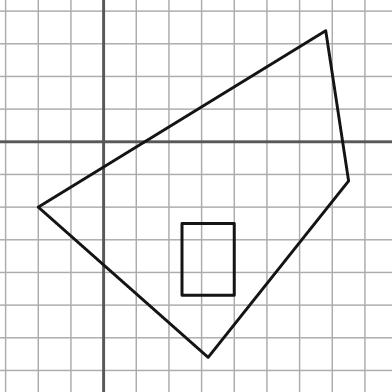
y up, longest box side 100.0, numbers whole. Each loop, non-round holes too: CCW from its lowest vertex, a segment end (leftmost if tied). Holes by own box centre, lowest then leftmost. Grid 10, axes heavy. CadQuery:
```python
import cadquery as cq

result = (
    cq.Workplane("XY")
    .moveTo(32.0, -66.0)
    .lineTo(75.0, -12.0)
    .lineTo(68.0, 34.0)
    .lineTo(-20.0, -20.0)
    .close()
    .moveTo(24.0, -47.0)
    .lineTo(40.0, -47.0)
    .lineTo(40.0, -25.0)
    .lineTo(24.0, -25.0)
    .close()
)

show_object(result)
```